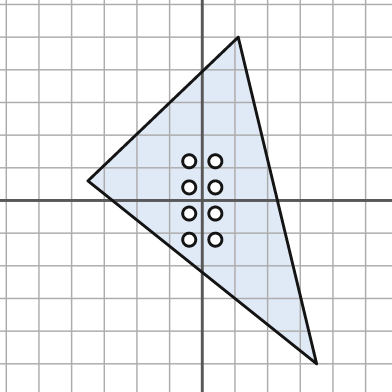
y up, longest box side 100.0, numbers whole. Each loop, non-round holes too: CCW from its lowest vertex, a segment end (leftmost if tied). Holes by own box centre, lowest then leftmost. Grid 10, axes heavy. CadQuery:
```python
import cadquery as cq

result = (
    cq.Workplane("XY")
    .moveTo(35.0, -50.0)
    .lineTo(11.0, 50.0)
    .lineTo(-35.0, 6.0)
    .close()
    .moveTo(-4.0, -12.0)
    .circle(2.0)
    .moveTo(4.0, -12.0)
    .circle(2.0)
    .moveTo(-4.0, -4.0)
    .circle(2.0)
    .moveTo(4.0, -4.0)
    .circle(2.0)
    .moveTo(-4.0, 4.0)
    .circle(2.0)
    .moveTo(4.0, 4.0)
    .circle(2.0)
    .moveTo(-4.0, 12.0)
    .circle(2.0)
    .moveTo(4.0, 12.0)
    .circle(2.0)
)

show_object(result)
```